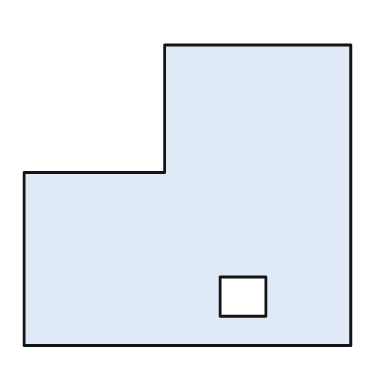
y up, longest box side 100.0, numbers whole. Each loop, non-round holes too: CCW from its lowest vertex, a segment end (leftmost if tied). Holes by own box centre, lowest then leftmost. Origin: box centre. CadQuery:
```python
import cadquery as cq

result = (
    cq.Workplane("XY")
    .moveTo(-50.0, -46.0)
    .lineTo(50.0, -46.0)
    .lineTo(50.0, 46.0)
    .lineTo(-7.0, 46.0)
    .lineTo(-7.0, 7.0)
    .lineTo(-50.0, 7.0)
    .close()
    .moveTo(10.0, -37.0)
    .lineTo(24.0, -37.0)
    .lineTo(24.0, -25.0)
    .lineTo(10.0, -25.0)
    .close()
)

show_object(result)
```